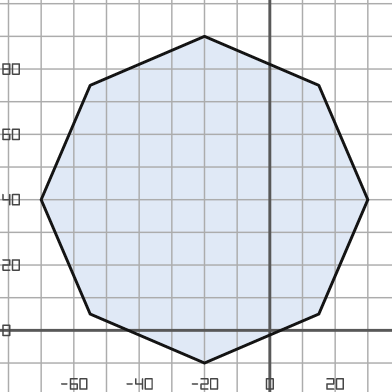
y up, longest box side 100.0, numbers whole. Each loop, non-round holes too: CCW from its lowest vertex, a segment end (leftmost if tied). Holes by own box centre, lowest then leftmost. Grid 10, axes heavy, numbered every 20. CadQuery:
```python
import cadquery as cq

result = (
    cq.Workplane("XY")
    .moveTo(-20.0, -10.0)
    .lineTo(15.0, 5.0)
    .lineTo(30.0, 40.0)
    .lineTo(15.0, 75.0)
    .lineTo(-20.0, 90.0)
    .lineTo(-55.0, 75.0)
    .lineTo(-70.0, 40.0)
    .lineTo(-55.0, 5.0)
    .close()
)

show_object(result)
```